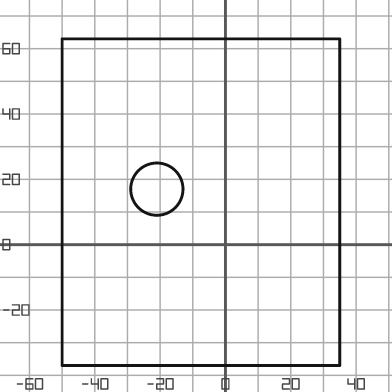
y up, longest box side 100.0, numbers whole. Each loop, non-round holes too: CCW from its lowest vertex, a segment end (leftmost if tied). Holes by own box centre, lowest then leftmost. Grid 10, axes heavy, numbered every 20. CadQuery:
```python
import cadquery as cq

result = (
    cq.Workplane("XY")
    .moveTo(-50.0, -37.0)
    .lineTo(35.0, -37.0)
    .lineTo(35.0, 63.0)
    .lineTo(-50.0, 63.0)
    .close()
    .moveTo(-21.0, 17.0)
    .circle(8.0)
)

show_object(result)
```